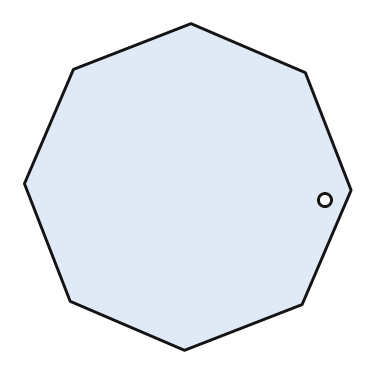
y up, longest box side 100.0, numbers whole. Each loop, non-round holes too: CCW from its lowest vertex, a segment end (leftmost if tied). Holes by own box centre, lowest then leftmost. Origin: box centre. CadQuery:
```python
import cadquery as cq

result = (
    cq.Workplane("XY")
    .moveTo(-1.0, -50.0)
    .lineTo(35.0, -36.0)
    .lineTo(50.0, -1.0)
    .lineTo(36.0, 35.0)
    .lineTo(1.0, 50.0)
    .lineTo(-35.0, 36.0)
    .lineTo(-50.0, 1.0)
    .lineTo(-36.0, -35.0)
    .close()
    .moveTo(42.0, -4.0)
    .circle(2.0)
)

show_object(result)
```